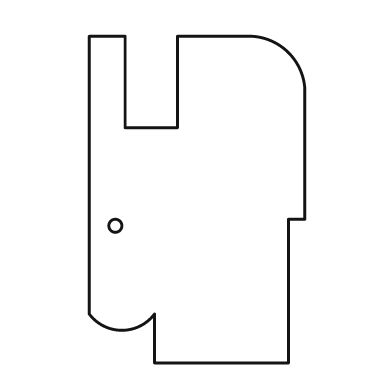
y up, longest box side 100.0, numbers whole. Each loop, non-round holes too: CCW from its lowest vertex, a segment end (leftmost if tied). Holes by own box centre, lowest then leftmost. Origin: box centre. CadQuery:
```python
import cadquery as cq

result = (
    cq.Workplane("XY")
    .moveTo(-13.0, -50.0)
    .lineTo(28.0, -50.0)
    .lineTo(28.0, -6.0)
    .lineTo(33.0, -6.0)
    .lineTo(33.0, 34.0)
    .threePointArc((28.0, 45.0), (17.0, 50.0))
    .lineTo(-6.0, 50.0)
    .lineTo(-6.0, 22.0)
    .lineTo(-22.0, 22.0)
    .lineTo(-22.0, 50.0)
    .lineTo(-33.0, 50.0)
    .lineTo(-33.0, -35.0)
    .threePointArc((-23.0, -40.0), (-13.0, -35.0))
    .close()
    .moveTo(-25.0, -8.0)
    .circle(2.0)
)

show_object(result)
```